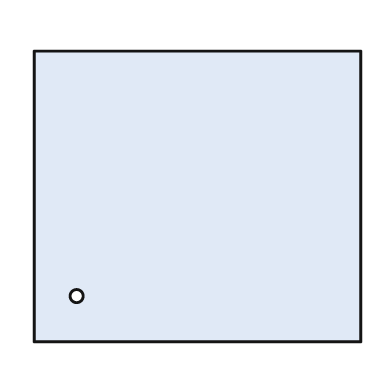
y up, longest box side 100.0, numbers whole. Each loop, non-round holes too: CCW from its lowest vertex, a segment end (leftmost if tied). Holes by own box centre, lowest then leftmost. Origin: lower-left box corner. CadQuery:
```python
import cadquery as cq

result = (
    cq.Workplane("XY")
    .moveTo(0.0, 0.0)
    .lineTo(100.0, 0.0)
    .lineTo(100.0, 89.0)
    .lineTo(0.0, 89.0)
    .close()
    .moveTo(13.0, 14.0)
    .circle(2.0)
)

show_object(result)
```